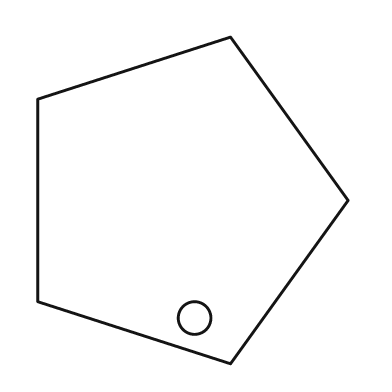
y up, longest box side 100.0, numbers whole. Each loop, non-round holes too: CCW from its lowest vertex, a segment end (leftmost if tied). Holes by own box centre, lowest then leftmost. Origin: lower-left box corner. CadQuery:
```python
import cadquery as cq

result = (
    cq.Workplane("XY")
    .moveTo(59.0, 0.0)
    .lineTo(95.0, 50.0)
    .lineTo(59.0, 100.0)
    .lineTo(0.0, 81.0)
    .lineTo(0.0, 19.0)
    .close()
    .moveTo(48.0, 14.0)
    .circle(5.0)
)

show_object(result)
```